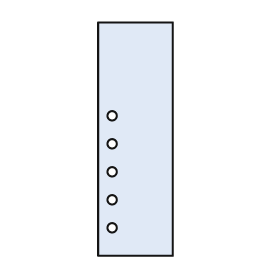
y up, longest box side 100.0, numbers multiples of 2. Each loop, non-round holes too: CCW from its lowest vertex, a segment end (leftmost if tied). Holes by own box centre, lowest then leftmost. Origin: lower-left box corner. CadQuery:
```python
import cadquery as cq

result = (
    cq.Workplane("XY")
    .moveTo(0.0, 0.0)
    .lineTo(32.0, 0.0)
    .lineTo(32.0, 100.0)
    .lineTo(0.0, 100.0)
    .close()
    .moveTo(6.0, 12.0)
    .circle(2.0)
    .moveTo(6.0, 24.0)
    .circle(2.0)
    .moveTo(6.0, 36.0)
    .circle(2.0)
    .moveTo(6.0, 48.0)
    .circle(2.0)
    .moveTo(6.0, 60.0)
    .circle(2.0)
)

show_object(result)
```